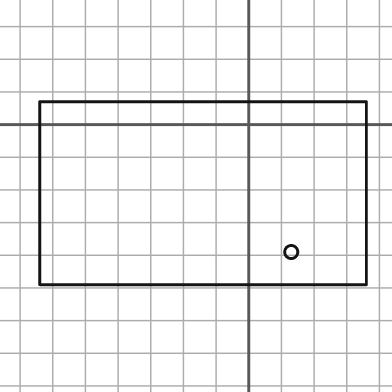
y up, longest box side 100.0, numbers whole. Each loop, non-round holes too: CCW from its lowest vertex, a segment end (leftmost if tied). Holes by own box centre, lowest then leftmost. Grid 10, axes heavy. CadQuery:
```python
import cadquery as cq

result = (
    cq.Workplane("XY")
    .moveTo(-64.0, -49.0)
    .lineTo(36.0, -49.0)
    .lineTo(36.0, 7.0)
    .lineTo(-64.0, 7.0)
    .close()
    .moveTo(13.0, -39.0)
    .circle(2.0)
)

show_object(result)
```